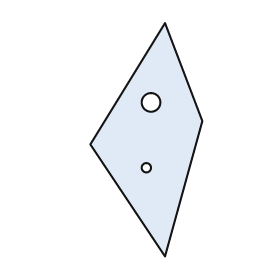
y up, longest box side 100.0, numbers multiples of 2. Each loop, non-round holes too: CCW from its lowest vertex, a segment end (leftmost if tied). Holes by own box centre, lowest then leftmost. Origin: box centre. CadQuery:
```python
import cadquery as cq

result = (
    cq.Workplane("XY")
    .moveTo(8.0, -50.0)
    .lineTo(24.0, 8.0)
    .lineTo(8.0, 50.0)
    .lineTo(-24.0, -2.0)
    .close()
    .moveTo(0.0, -12.0)
    .circle(2.0)
    .moveTo(2.0, 16.0)
    .circle(4.0)
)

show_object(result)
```